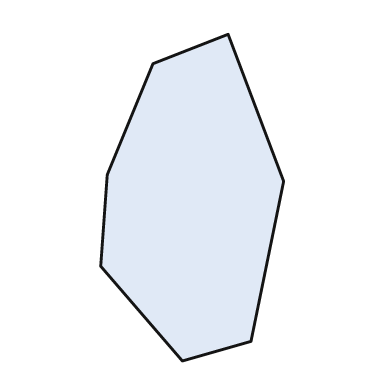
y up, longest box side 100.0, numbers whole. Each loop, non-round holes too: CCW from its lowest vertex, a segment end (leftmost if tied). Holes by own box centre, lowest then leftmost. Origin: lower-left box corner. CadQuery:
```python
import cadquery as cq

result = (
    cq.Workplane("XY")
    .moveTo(25.0, 0.0)
    .lineTo(46.0, 6.0)
    .lineTo(56.0, 55.0)
    .lineTo(39.0, 100.0)
    .lineTo(16.0, 91.0)
    .lineTo(2.0, 57.0)
    .lineTo(0.0, 29.0)
    .close()
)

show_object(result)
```